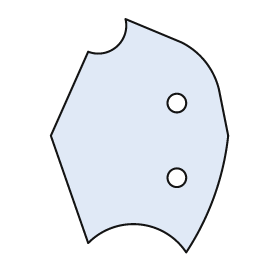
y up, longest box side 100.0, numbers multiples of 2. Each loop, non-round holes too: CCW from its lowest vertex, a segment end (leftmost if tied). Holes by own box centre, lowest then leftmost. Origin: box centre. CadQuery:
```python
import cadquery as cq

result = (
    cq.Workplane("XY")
    .moveTo(20.0, -50.0)
    .threePointArc((32.0, -26.0), (38.0, 0.0))
    .lineTo(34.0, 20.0)
    .threePointArc((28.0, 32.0), (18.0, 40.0))
    .lineTo(-6.0, 50.0)
    .threePointArc((-10.0, 38.0), (-22.0, 36.0))
    .lineTo(-38.0, 0.0)
    .lineTo(-22.0, -46.0)
    .threePointArc((0.0, -38.0), (20.0, -50.0))
    .close()
    .moveTo(16.0, -18.0)
    .circle(4.0)
    .moveTo(16.0, 14.0)
    .circle(4.0)
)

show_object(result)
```